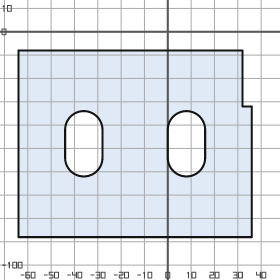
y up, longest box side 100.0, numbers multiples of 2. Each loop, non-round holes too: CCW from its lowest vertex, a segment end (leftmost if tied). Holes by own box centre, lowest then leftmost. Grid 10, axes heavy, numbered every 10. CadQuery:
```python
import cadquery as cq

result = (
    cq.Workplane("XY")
    .moveTo(-64.0, -88.0)
    .lineTo(36.0, -88.0)
    .lineTo(36.0, -32.0)
    .lineTo(32.0, -32.0)
    .lineTo(32.0, -8.0)
    .lineTo(-64.0, -8.0)
    .close()
    .moveTo(-44.0, -54.0)
    .threePointArc((-36.0, -62.0), (-28.0, -54.0))
    .lineTo(-28.0, -42.0)
    .threePointArc((-36.0, -34.0), (-44.0, -42.0))
    .close()
    .moveTo(0.0, -54.0)
    .threePointArc((8.0, -62.0), (16.0, -54.0))
    .lineTo(16.0, -42.0)
    .threePointArc((8.0, -34.0), (0.0, -42.0))
    .close()
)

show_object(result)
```